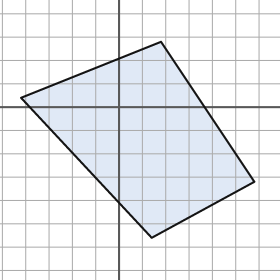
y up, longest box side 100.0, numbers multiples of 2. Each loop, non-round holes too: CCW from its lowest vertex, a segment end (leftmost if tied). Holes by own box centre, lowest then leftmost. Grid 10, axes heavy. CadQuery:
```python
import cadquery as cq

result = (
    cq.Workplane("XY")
    .moveTo(14.0, -56.0)
    .lineTo(58.0, -32.0)
    .lineTo(18.0, 28.0)
    .lineTo(-42.0, 4.0)
    .close()
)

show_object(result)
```